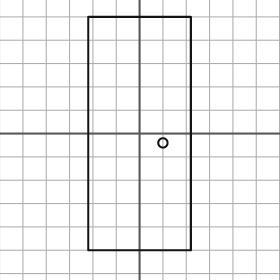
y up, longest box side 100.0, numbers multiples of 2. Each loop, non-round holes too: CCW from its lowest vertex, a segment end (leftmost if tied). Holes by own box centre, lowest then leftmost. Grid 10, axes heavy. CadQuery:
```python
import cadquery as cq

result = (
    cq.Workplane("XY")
    .moveTo(-22.0, -50.0)
    .lineTo(22.0, -50.0)
    .lineTo(22.0, 50.0)
    .lineTo(-22.0, 50.0)
    .close()
    .moveTo(10.0, -4.0)
    .circle(2.0)
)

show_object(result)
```